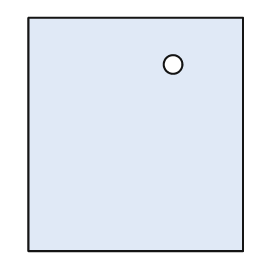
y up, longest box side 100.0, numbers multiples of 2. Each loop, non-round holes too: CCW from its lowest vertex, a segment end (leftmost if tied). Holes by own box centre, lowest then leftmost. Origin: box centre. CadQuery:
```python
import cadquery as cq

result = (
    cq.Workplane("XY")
    .moveTo(-46.0, -50.0)
    .lineTo(46.0, -50.0)
    .lineTo(46.0, 50.0)
    .lineTo(-46.0, 50.0)
    .close()
    .moveTo(16.0, 30.0)
    .circle(4.0)
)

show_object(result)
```